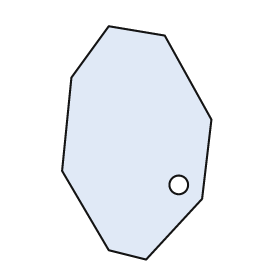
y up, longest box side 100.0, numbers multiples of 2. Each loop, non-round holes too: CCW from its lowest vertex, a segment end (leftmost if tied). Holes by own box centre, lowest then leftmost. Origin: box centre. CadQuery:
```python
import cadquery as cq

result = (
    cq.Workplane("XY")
    .moveTo(4.0, -50.0)
    .lineTo(28.0, -24.0)
    .lineTo(32.0, 10.0)
    .lineTo(12.0, 46.0)
    .lineTo(-12.0, 50.0)
    .lineTo(-28.0, 28.0)
    .lineTo(-32.0, -12.0)
    .lineTo(-12.0, -46.0)
    .close()
    .moveTo(18.0, -18.0)
    .circle(4.0)
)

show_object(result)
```